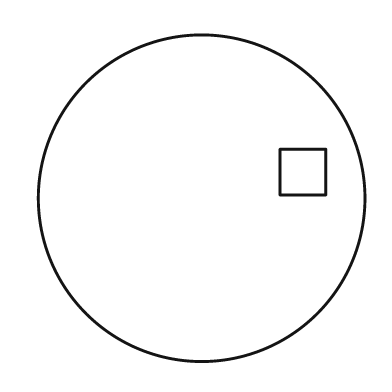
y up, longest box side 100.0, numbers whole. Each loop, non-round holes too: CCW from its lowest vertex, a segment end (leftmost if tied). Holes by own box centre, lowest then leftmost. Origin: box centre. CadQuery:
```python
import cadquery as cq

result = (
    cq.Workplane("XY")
    .moveTo(0.0, 0.0)
    .circle(50.0)
    .moveTo(24.0, 1.0)
    .lineTo(38.0, 1.0)
    .lineTo(38.0, 15.0)
    .lineTo(24.0, 15.0)
    .close()
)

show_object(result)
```